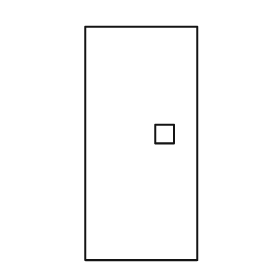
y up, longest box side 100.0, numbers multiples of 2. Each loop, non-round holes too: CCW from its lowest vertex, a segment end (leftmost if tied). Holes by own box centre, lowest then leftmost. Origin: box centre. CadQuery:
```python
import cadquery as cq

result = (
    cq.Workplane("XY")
    .moveTo(-24.0, -50.0)
    .lineTo(24.0, -50.0)
    .lineTo(24.0, 50.0)
    .lineTo(-24.0, 50.0)
    .close()
    .moveTo(6.0, 0.0)
    .lineTo(14.0, 0.0)
    .lineTo(14.0, 8.0)
    .lineTo(6.0, 8.0)
    .close()
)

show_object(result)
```